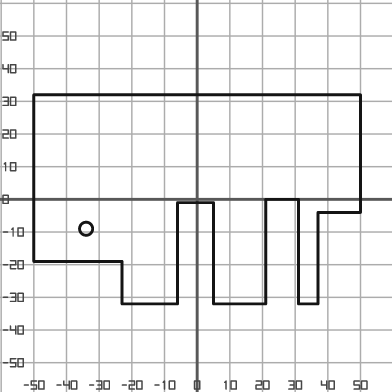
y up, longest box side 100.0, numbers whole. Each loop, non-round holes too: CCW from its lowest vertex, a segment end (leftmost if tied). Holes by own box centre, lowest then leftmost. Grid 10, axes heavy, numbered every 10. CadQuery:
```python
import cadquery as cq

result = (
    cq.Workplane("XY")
    .moveTo(-23.0, -32.0)
    .lineTo(-6.0, -32.0)
    .lineTo(-6.0, -1.0)
    .lineTo(5.0, -1.0)
    .lineTo(5.0, -32.0)
    .lineTo(21.0, -32.0)
    .lineTo(21.0, 0.0)
    .lineTo(31.0, 0.0)
    .lineTo(31.0, -32.0)
    .lineTo(37.0, -32.0)
    .lineTo(37.0, -4.0)
    .lineTo(50.0, -4.0)
    .lineTo(50.0, 32.0)
    .lineTo(-50.0, 32.0)
    .lineTo(-50.0, -19.0)
    .lineTo(-23.0, -19.0)
    .close()
    .moveTo(-34.0, -9.0)
    .circle(2.0)
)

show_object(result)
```